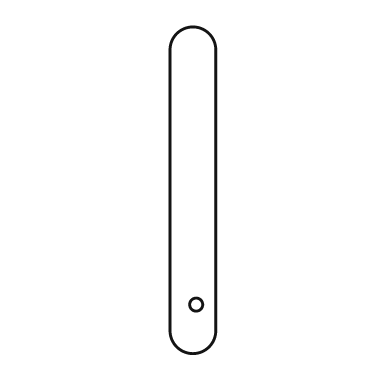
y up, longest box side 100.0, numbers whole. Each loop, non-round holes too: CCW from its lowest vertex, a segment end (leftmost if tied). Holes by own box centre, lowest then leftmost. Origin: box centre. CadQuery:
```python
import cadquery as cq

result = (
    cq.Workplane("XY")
    .moveTo(-7.0, -43.0)
    .threePointArc((0.0, -50.0), (7.0, -43.0))
    .lineTo(7.0, 43.0)
    .threePointArc((0.0, 50.0), (-7.0, 43.0))
    .close()
    .moveTo(1.0, -35.0)
    .circle(2.0)
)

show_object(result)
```